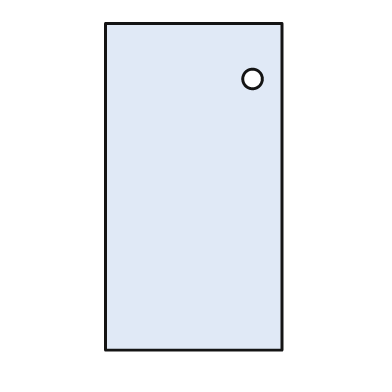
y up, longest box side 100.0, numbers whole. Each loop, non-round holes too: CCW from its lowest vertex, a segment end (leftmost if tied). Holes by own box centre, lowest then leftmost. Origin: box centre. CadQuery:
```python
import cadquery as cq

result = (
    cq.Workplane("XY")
    .moveTo(-27.0, -50.0)
    .lineTo(27.0, -50.0)
    .lineTo(27.0, 50.0)
    .lineTo(-27.0, 50.0)
    .close()
    .moveTo(18.0, 33.0)
    .circle(3.0)
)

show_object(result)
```